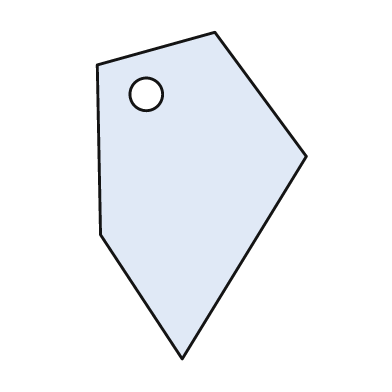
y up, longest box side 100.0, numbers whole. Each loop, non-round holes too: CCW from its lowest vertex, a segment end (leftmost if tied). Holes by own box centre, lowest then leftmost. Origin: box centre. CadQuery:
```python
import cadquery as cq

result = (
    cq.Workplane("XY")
    .moveTo(-6.0, -50.0)
    .lineTo(32.0, 12.0)
    .lineTo(4.0, 50.0)
    .lineTo(-32.0, 40.0)
    .lineTo(-31.0, -12.0)
    .close()
    .moveTo(-17.0, 31.0)
    .circle(5.0)
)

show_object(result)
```